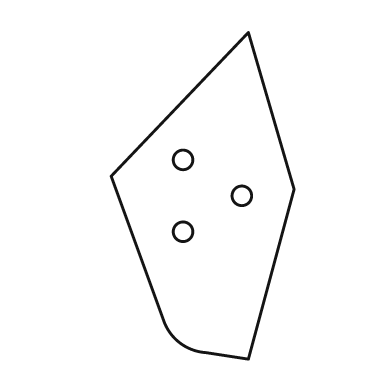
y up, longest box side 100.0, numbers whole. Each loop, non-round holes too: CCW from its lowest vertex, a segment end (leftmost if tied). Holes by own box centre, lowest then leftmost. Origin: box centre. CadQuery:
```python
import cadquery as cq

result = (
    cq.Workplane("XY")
    .moveTo(14.0, -50.0)
    .lineTo(28.0, 2.0)
    .lineTo(14.0, 50.0)
    .lineTo(-28.0, 6.0)
    .lineTo(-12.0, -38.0)
    .threePointArc((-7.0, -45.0), (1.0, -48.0))
    .close()
    .moveTo(-6.0, -11.0)
    .circle(3.0)
    .moveTo(12.0, 0.0)
    .circle(3.0)
    .moveTo(-6.0, 11.0)
    .circle(3.0)
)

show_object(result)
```